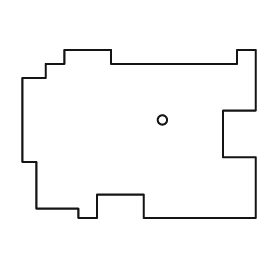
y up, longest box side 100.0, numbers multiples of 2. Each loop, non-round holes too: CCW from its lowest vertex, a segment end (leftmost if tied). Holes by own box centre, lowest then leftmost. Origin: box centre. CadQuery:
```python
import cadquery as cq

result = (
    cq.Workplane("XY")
    .moveTo(-26.0, -36.0)
    .lineTo(-18.0, -36.0)
    .lineTo(-18.0, -26.0)
    .lineTo(2.0, -26.0)
    .lineTo(2.0, -36.0)
    .lineTo(50.0, -36.0)
    .lineTo(50.0, -10.0)
    .lineTo(36.0, -10.0)
    .lineTo(36.0, 10.0)
    .lineTo(50.0, 10.0)
    .lineTo(50.0, 36.0)
    .lineTo(42.0, 36.0)
    .lineTo(42.0, 30.0)
    .lineTo(-12.0, 30.0)
    .lineTo(-12.0, 36.0)
    .lineTo(-32.0, 36.0)
    .lineTo(-32.0, 30.0)
    .lineTo(-40.0, 30.0)
    .lineTo(-40.0, 24.0)
    .lineTo(-50.0, 24.0)
    .lineTo(-50.0, -12.0)
    .lineTo(-44.0, -12.0)
    .lineTo(-44.0, -32.0)
    .lineTo(-26.0, -32.0)
    .close()
    .moveTo(10.0, 6.0)
    .circle(2.0)
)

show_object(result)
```